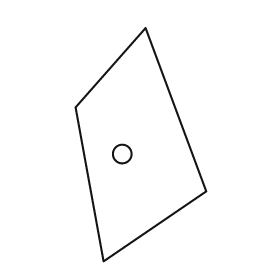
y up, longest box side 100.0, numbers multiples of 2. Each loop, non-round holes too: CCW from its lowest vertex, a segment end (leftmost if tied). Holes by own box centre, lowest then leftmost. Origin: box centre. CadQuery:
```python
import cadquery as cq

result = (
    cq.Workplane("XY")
    .moveTo(-16.0, -50.0)
    .lineTo(28.0, -20.0)
    .lineTo(2.0, 50.0)
    .lineTo(-28.0, 16.0)
    .close()
    .moveTo(-8.0, -4.0)
    .circle(4.0)
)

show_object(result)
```